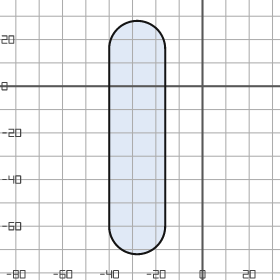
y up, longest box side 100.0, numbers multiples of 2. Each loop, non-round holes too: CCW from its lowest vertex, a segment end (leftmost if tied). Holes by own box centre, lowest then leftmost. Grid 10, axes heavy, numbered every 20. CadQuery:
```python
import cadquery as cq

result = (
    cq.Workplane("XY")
    .moveTo(-40.0, -60.0)
    .threePointArc((-28.0, -72.0), (-16.0, -60.0))
    .lineTo(-16.0, 16.0)
    .threePointArc((-28.0, 28.0), (-40.0, 16.0))
    .close()
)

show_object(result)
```